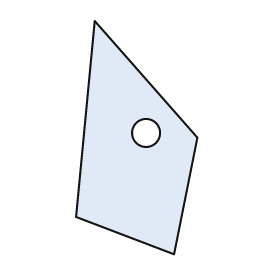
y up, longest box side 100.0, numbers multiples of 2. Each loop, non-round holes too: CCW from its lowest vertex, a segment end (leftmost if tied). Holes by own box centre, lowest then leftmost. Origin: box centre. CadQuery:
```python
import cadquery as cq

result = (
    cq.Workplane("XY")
    .moveTo(16.0, -50.0)
    .lineTo(26.0, 0.0)
    .lineTo(-18.0, 50.0)
    .lineTo(-26.0, -34.0)
    .close()
    .moveTo(4.0, 2.0)
    .circle(6.0)
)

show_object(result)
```